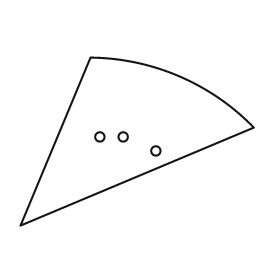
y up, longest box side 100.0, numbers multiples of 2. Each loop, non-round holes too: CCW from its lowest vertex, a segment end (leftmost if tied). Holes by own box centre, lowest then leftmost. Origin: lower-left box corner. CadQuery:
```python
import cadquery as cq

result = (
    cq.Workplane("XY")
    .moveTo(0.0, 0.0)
    .lineTo(100.0, 42.0)
    .threePointArc((68.0, 64.0), (30.0, 72.0))
    .close()
    .moveTo(58.0, 32.0)
    .circle(2.0)
    .moveTo(34.0, 38.0)
    .circle(2.0)
    .moveTo(44.0, 38.0)
    .circle(2.0)
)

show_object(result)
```